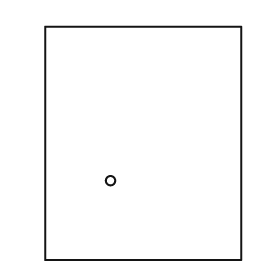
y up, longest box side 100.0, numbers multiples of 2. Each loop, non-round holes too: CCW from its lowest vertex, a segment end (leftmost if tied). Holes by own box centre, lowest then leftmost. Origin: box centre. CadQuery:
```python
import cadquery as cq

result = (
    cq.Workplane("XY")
    .moveTo(-42.0, -50.0)
    .lineTo(42.0, -50.0)
    .lineTo(42.0, 50.0)
    .lineTo(-42.0, 50.0)
    .close()
    .moveTo(-14.0, -16.0)
    .circle(2.0)
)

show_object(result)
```